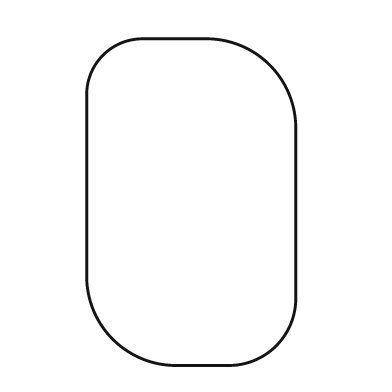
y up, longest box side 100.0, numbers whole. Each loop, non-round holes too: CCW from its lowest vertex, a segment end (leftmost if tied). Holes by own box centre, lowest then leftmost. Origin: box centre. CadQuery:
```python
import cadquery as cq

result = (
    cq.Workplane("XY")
    .moveTo(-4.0, -50.0)
    .lineTo(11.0, -50.0)
    .threePointArc((26.0, -44.0), (32.0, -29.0))
    .lineTo(32.0, 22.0)
    .threePointArc((24.0, 42.0), (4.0, 50.0))
    .lineTo(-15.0, 50.0)
    .threePointArc((-27.0, 45.0), (-32.0, 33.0))
    .lineTo(-32.0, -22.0)
    .threePointArc((-24.0, -42.0), (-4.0, -50.0))
    .close()
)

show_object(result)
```